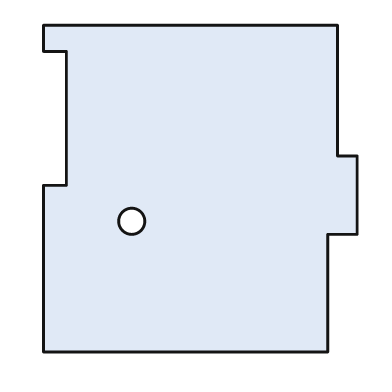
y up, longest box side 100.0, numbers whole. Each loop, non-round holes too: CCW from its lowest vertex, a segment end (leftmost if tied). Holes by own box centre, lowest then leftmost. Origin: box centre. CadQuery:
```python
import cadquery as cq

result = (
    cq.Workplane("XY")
    .moveTo(-48.0, -50.0)
    .lineTo(39.0, -50.0)
    .lineTo(39.0, -14.0)
    .lineTo(48.0, -14.0)
    .lineTo(48.0, 10.0)
    .lineTo(42.0, 10.0)
    .lineTo(42.0, 50.0)
    .lineTo(-48.0, 50.0)
    .lineTo(-48.0, 42.0)
    .lineTo(-41.0, 42.0)
    .lineTo(-41.0, 1.0)
    .lineTo(-48.0, 1.0)
    .close()
    .moveTo(-21.0, -10.0)
    .circle(4.0)
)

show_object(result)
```